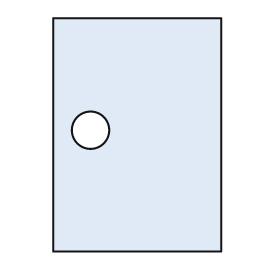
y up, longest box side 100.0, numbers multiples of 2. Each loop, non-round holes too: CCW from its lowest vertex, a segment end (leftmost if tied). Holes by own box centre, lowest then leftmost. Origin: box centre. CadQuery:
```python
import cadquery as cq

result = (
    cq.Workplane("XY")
    .moveTo(-36.0, -50.0)
    .lineTo(36.0, -50.0)
    .lineTo(36.0, 50.0)
    .lineTo(-36.0, 50.0)
    .close()
    .moveTo(-20.0, 2.0)
    .circle(8.0)
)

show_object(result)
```